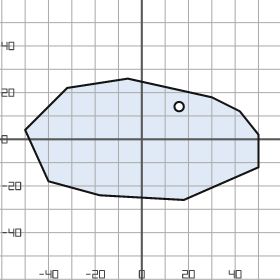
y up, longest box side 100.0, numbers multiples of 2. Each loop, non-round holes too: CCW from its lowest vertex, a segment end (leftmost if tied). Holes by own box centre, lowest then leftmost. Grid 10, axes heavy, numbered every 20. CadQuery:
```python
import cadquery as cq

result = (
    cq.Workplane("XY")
    .moveTo(18.0, -26.0)
    .lineTo(50.0, -12.0)
    .lineTo(50.0, 2.0)
    .lineTo(42.0, 12.0)
    .lineTo(30.0, 18.0)
    .lineTo(-6.0, 26.0)
    .lineTo(-32.0, 22.0)
    .lineTo(-50.0, 4.0)
    .lineTo(-40.0, -18.0)
    .lineTo(-18.0, -24.0)
    .close()
    .moveTo(16.0, 14.0)
    .circle(2.0)
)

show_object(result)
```